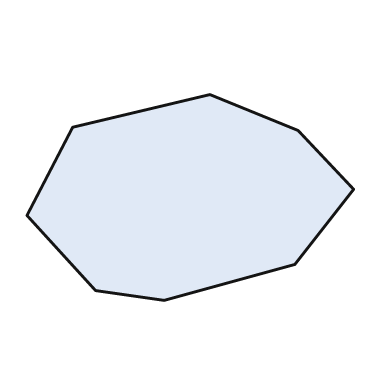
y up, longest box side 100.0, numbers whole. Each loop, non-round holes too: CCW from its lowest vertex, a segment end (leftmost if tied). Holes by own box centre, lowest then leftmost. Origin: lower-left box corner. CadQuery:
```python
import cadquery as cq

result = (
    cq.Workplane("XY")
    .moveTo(42.0, 0.0)
    .lineTo(82.0, 11.0)
    .lineTo(100.0, 34.0)
    .lineTo(83.0, 52.0)
    .lineTo(56.0, 63.0)
    .lineTo(14.0, 53.0)
    .lineTo(0.0, 26.0)
    .lineTo(21.0, 3.0)
    .close()
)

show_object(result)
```